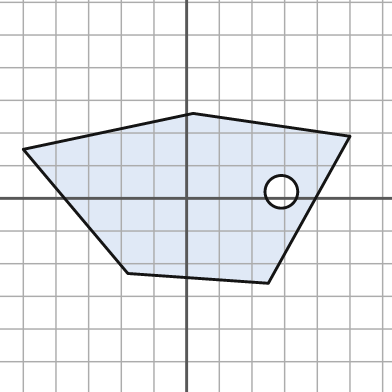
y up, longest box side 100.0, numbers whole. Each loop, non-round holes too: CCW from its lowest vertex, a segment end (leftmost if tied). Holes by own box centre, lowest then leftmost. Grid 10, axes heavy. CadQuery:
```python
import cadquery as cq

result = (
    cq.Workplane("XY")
    .moveTo(25.0, -26.0)
    .lineTo(50.0, 19.0)
    .lineTo(2.0, 26.0)
    .lineTo(-50.0, 15.0)
    .lineTo(-18.0, -23.0)
    .close()
    .moveTo(29.0, 2.0)
    .circle(5.0)
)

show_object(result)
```